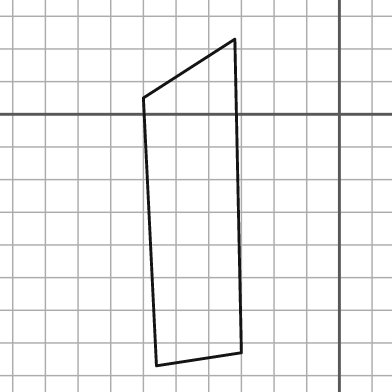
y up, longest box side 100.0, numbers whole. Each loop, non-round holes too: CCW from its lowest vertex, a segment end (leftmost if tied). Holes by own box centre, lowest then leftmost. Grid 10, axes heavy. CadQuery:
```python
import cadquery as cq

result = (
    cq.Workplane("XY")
    .moveTo(-56.0, -77.0)
    .lineTo(-30.0, -73.0)
    .lineTo(-32.0, 23.0)
    .lineTo(-60.0, 5.0)
    .close()
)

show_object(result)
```